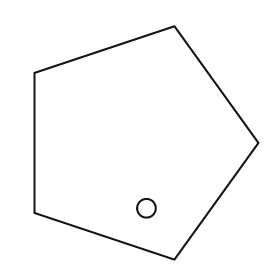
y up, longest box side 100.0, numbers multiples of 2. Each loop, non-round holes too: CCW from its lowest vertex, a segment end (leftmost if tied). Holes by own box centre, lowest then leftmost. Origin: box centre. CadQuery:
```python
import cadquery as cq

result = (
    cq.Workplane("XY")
    .moveTo(12.0, -50.0)
    .lineTo(48.0, 0.0)
    .lineTo(12.0, 50.0)
    .lineTo(-48.0, 30.0)
    .lineTo(-48.0, -30.0)
    .close()
    .moveTo(0.0, -28.0)
    .circle(4.0)
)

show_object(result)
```